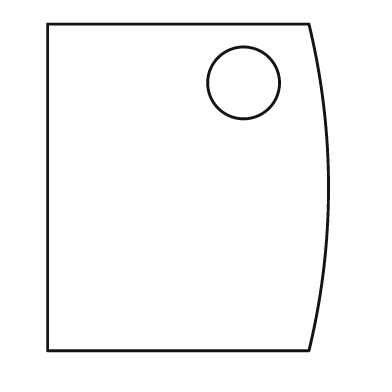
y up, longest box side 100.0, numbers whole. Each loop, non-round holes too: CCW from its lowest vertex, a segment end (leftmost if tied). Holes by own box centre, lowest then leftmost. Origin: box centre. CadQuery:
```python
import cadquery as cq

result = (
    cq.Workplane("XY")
    .moveTo(-43.0, -50.0)
    .lineTo(37.0, -50.0)
    .threePointArc((43.0, 0.0), (37.0, 50.0))
    .lineTo(-43.0, 50.0)
    .close()
    .moveTo(17.0, 32.0)
    .circle(11.0)
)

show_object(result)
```